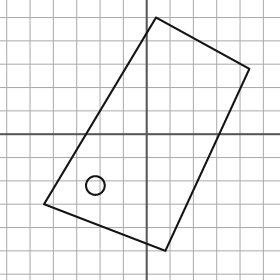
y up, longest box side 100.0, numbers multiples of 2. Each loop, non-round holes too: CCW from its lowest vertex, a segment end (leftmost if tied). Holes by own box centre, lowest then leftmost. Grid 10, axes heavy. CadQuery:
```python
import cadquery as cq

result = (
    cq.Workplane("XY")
    .moveTo(8.0, -50.0)
    .lineTo(44.0, 28.0)
    .lineTo(4.0, 50.0)
    .lineTo(-44.0, -30.0)
    .close()
    .moveTo(-22.0, -22.0)
    .circle(4.0)
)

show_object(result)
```